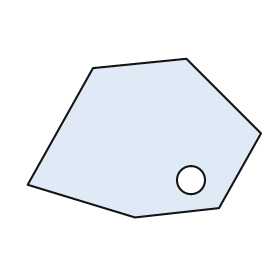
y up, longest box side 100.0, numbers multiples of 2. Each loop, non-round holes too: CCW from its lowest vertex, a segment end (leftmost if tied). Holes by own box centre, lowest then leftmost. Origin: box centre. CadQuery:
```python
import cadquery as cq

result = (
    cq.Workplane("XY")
    .moveTo(-4.0, -34.0)
    .lineTo(32.0, -30.0)
    .lineTo(50.0, 2.0)
    .lineTo(18.0, 34.0)
    .lineTo(-22.0, 30.0)
    .lineTo(-50.0, -20.0)
    .close()
    .moveTo(20.0, -18.0)
    .circle(6.0)
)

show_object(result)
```